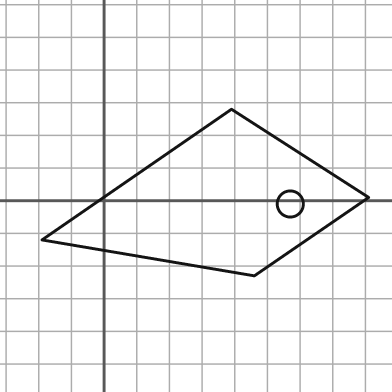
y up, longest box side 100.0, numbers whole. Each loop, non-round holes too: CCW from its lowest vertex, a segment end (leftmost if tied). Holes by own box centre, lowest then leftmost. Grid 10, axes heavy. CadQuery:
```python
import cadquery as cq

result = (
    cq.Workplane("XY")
    .moveTo(46.0, -23.0)
    .lineTo(81.0, 1.0)
    .lineTo(39.0, 28.0)
    .lineTo(-19.0, -12.0)
    .close()
    .moveTo(57.0, -1.0)
    .circle(4.0)
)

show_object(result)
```